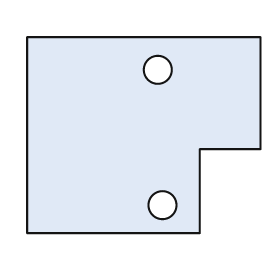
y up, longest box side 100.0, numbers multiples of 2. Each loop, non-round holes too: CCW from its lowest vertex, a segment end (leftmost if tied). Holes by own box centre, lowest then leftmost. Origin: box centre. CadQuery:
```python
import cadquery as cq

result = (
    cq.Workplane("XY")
    .moveTo(-50.0, -42.0)
    .lineTo(24.0, -42.0)
    .lineTo(24.0, -6.0)
    .lineTo(50.0, -6.0)
    .lineTo(50.0, 42.0)
    .lineTo(-50.0, 42.0)
    .close()
    .moveTo(8.0, -30.0)
    .circle(6.0)
    .moveTo(6.0, 28.0)
    .circle(6.0)
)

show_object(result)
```